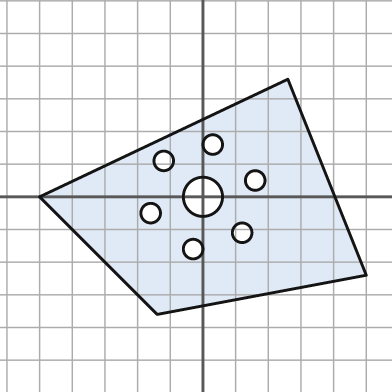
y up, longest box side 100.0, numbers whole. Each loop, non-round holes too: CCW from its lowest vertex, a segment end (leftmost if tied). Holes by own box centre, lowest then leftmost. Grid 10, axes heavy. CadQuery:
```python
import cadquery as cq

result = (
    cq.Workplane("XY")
    .moveTo(-14.0, -36.0)
    .lineTo(50.0, -24.0)
    .lineTo(26.0, 36.0)
    .lineTo(-50.0, 0.0)
    .close()
    .moveTo(-3.0, -16.0)
    .circle(3.0)
    .moveTo(12.0, -11.0)
    .circle(3.0)
    .moveTo(-16.0, -5.0)
    .circle(3.0)
    .moveTo(0.0, 0.0)
    .circle(6.0)
    .moveTo(16.0, 5.0)
    .circle(3.0)
    .moveTo(-12.0, 11.0)
    .circle(3.0)
    .moveTo(3.0, 16.0)
    .circle(3.0)
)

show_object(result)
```